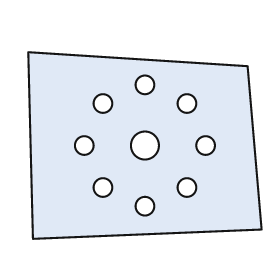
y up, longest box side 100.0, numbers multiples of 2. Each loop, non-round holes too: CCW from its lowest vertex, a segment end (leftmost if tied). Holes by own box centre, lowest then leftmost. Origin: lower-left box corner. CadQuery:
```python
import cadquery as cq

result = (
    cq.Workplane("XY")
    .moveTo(2.0, 0.0)
    .lineTo(100.0, 4.0)
    .lineTo(94.0, 74.0)
    .lineTo(0.0, 80.0)
    .close()
    .moveTo(50.0, 14.0)
    .circle(4.0)
    .moveTo(32.0, 22.0)
    .circle(4.0)
    .moveTo(68.0, 22.0)
    .circle(4.0)
    .moveTo(24.0, 40.0)
    .circle(4.0)
    .moveTo(50.0, 40.0)
    .circle(6.0)
    .moveTo(76.0, 40.0)
    .circle(4.0)
    .moveTo(32.0, 58.0)
    .circle(4.0)
    .moveTo(68.0, 58.0)
    .circle(4.0)
    .moveTo(50.0, 66.0)
    .circle(4.0)
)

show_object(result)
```